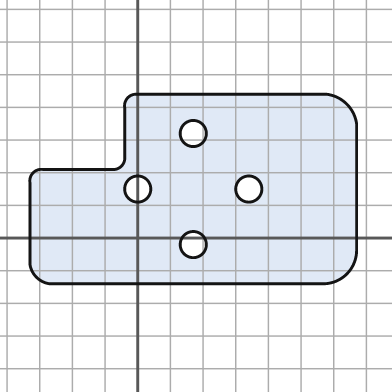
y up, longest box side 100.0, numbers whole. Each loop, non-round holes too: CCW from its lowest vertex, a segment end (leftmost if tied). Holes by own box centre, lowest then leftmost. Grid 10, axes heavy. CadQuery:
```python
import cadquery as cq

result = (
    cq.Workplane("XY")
    .moveTo(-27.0, -14.0)
    .lineTo(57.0, -14.0)
    .threePointArc((64.0, -11.0), (67.0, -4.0))
    .lineTo(67.0, 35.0)
    .threePointArc((64.0, 41.0), (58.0, 44.0))
    .lineTo(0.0, 44.0)
    .threePointArc((-3.0, 43.0), (-4.0, 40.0))
    .lineTo(-4.0, 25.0)
    .threePointArc((-5.0, 22.0), (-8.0, 21.0))
    .lineTo(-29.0, 21.0)
    .threePointArc((-32.0, 20.0), (-33.0, 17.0))
    .lineTo(-33.0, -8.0)
    .threePointArc((-31.0, -12.0), (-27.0, -14.0))
    .close()
    .moveTo(17.0, -2.0)
    .circle(4.0)
    .moveTo(0.0, 15.0)
    .circle(4.0)
    .moveTo(34.0, 15.0)
    .circle(4.0)
    .moveTo(17.0, 32.0)
    .circle(4.0)
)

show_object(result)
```